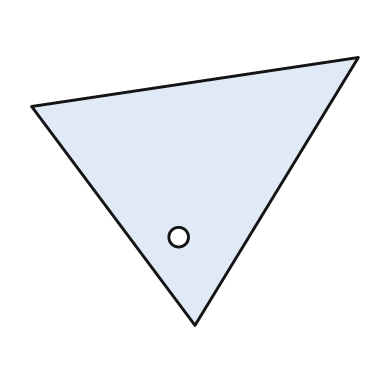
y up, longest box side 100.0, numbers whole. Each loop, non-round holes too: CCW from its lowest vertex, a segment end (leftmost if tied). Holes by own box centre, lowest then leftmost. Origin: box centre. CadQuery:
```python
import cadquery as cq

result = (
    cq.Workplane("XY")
    .moveTo(0.0, -41.0)
    .lineTo(50.0, 41.0)
    .lineTo(-50.0, 26.0)
    .close()
    .moveTo(-5.0, -14.0)
    .circle(3.0)
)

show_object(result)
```